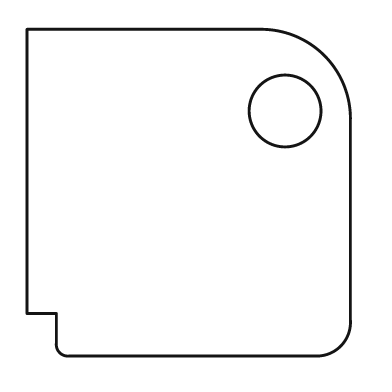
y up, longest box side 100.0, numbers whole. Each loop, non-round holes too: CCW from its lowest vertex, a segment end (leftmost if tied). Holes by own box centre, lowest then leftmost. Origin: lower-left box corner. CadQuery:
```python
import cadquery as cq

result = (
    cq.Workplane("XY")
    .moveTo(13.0, 0.0)
    .lineTo(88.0, 0.0)
    .threePointArc((96.0, 3.0), (99.0, 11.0))
    .lineTo(99.0, 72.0)
    .threePointArc((91.0, 92.0), (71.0, 100.0))
    .lineTo(0.0, 100.0)
    .lineTo(0.0, 13.0)
    .lineTo(9.0, 13.0)
    .lineTo(9.0, 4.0)
    .threePointArc((10.0, 1.0), (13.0, 0.0))
    .close()
    .moveTo(79.0, 75.0)
    .circle(11.0)
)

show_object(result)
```